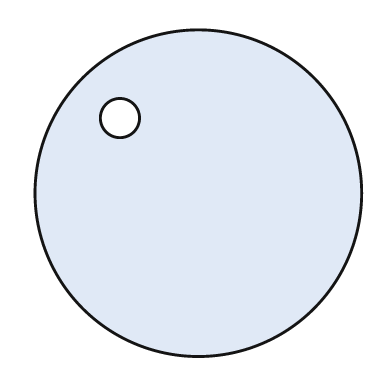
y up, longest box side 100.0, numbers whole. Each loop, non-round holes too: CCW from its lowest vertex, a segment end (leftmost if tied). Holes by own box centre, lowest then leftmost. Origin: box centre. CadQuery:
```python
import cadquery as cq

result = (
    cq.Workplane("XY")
    .moveTo(0.0, 0.0)
    .circle(50.0)
    .moveTo(-24.0, 23.0)
    .circle(6.0)
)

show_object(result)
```